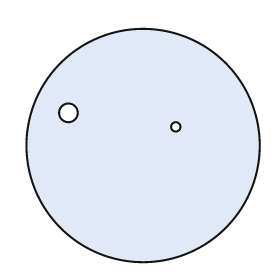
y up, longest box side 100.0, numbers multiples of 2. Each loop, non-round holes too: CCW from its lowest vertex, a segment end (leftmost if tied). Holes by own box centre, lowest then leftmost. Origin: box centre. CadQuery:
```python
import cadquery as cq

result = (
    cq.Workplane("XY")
    .moveTo(0.0, 0.0)
    .circle(50.0)
    .moveTo(14.0, 8.0)
    .circle(2.0)
    .moveTo(-32.0, 14.0)
    .circle(4.0)
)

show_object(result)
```